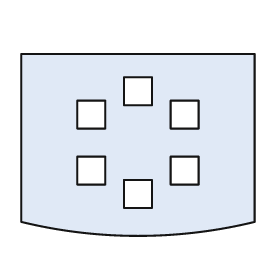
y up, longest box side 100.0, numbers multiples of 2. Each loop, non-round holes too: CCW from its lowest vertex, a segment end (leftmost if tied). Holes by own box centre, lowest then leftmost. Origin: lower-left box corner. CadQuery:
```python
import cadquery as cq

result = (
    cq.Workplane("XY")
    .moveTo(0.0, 6.0)
    .threePointArc((50.0, 0.0), (100.0, 6.0))
    .lineTo(100.0, 78.0)
    .lineTo(0.0, 78.0)
    .close()
    .moveTo(44.0, 12.0)
    .lineTo(56.0, 12.0)
    .lineTo(56.0, 24.0)
    .lineTo(44.0, 24.0)
    .close()
    .moveTo(24.0, 22.0)
    .lineTo(36.0, 22.0)
    .lineTo(36.0, 34.0)
    .lineTo(24.0, 34.0)
    .close()
    .moveTo(64.0, 22.0)
    .lineTo(76.0, 22.0)
    .lineTo(76.0, 34.0)
    .lineTo(64.0, 34.0)
    .close()
    .moveTo(24.0, 46.0)
    .lineTo(36.0, 46.0)
    .lineTo(36.0, 58.0)
    .lineTo(24.0, 58.0)
    .close()
    .moveTo(64.0, 46.0)
    .lineTo(76.0, 46.0)
    .lineTo(76.0, 58.0)
    .lineTo(64.0, 58.0)
    .close()
    .moveTo(44.0, 56.0)
    .lineTo(56.0, 56.0)
    .lineTo(56.0, 68.0)
    .lineTo(44.0, 68.0)
    .close()
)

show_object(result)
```